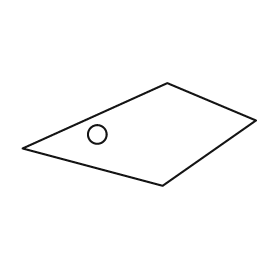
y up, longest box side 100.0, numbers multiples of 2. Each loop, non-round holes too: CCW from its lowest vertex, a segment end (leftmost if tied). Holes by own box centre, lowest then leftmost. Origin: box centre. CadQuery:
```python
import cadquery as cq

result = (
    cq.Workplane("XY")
    .moveTo(10.0, -22.0)
    .lineTo(50.0, 6.0)
    .lineTo(12.0, 22.0)
    .lineTo(-50.0, -6.0)
    .close()
    .moveTo(-18.0, 0.0)
    .circle(4.0)
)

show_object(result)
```